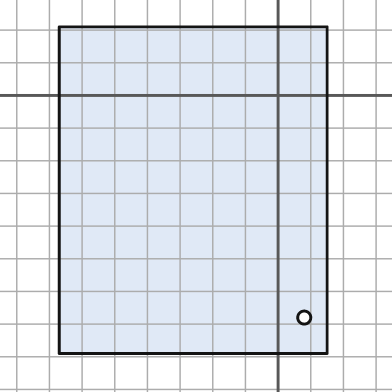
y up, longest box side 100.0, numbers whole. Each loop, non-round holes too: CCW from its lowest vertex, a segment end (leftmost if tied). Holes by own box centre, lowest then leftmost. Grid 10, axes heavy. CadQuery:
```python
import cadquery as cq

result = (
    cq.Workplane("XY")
    .moveTo(-67.0, -79.0)
    .lineTo(15.0, -79.0)
    .lineTo(15.0, 21.0)
    .lineTo(-67.0, 21.0)
    .close()
    .moveTo(8.0, -68.0)
    .circle(2.0)
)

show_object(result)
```